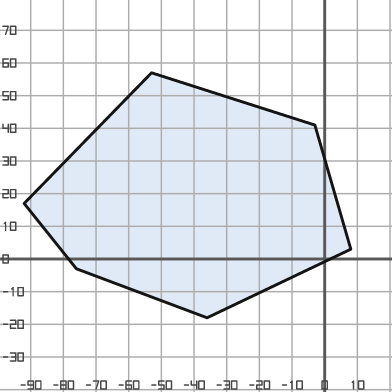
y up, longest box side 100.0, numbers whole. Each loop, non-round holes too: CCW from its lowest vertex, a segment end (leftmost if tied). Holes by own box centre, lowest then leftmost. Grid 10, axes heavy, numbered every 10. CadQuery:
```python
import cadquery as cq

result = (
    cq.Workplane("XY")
    .moveTo(-36.0, -18.0)
    .lineTo(8.0, 3.0)
    .lineTo(-3.0, 41.0)
    .lineTo(-53.0, 57.0)
    .lineTo(-92.0, 17.0)
    .lineTo(-76.0, -3.0)
    .close()
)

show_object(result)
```